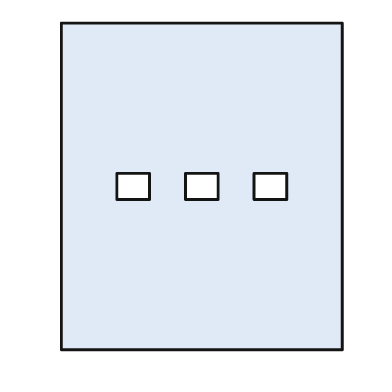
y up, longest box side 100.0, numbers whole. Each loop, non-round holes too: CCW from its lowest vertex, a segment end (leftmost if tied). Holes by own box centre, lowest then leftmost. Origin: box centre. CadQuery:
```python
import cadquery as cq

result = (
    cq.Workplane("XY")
    .moveTo(-43.0, -50.0)
    .lineTo(43.0, -50.0)
    .lineTo(43.0, 50.0)
    .lineTo(-43.0, 50.0)
    .close()
    .moveTo(-26.0, -4.0)
    .lineTo(-16.0, -4.0)
    .lineTo(-16.0, 4.0)
    .lineTo(-26.0, 4.0)
    .close()
    .moveTo(-5.0, -4.0)
    .lineTo(5.0, -4.0)
    .lineTo(5.0, 4.0)
    .lineTo(-5.0, 4.0)
    .close()
    .moveTo(16.0, -4.0)
    .lineTo(26.0, -4.0)
    .lineTo(26.0, 4.0)
    .lineTo(16.0, 4.0)
    .close()
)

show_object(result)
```